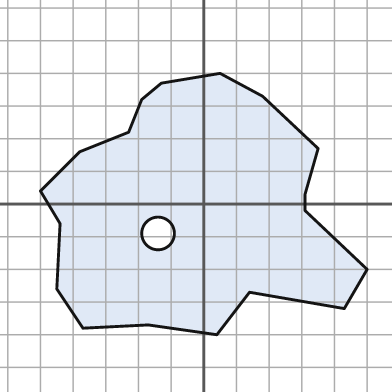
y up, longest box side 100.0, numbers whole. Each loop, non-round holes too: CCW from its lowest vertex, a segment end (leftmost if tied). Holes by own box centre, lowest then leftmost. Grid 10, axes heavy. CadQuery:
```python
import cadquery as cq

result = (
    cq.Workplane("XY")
    .moveTo(4.0, -40.0)
    .lineTo(14.0, -27.0)
    .lineTo(43.0, -32.0)
    .lineTo(50.0, -20.0)
    .lineTo(31.0, -2.0)
    .lineTo(31.0, 3.0)
    .lineTo(35.0, 17.0)
    .lineTo(18.0, 33.0)
    .lineTo(5.0, 40.0)
    .lineTo(-13.0, 37.0)
    .lineTo(-19.0, 32.0)
    .lineTo(-23.0, 22.0)
    .lineTo(-38.0, 16.0)
    .lineTo(-50.0, 4.0)
    .lineTo(-44.0, -6.0)
    .lineTo(-45.0, -26.0)
    .lineTo(-37.0, -38.0)
    .lineTo(-17.0, -37.0)
    .close()
    .moveTo(-14.0, -9.0)
    .circle(5.0)
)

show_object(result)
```